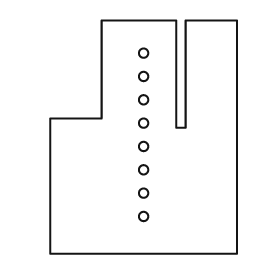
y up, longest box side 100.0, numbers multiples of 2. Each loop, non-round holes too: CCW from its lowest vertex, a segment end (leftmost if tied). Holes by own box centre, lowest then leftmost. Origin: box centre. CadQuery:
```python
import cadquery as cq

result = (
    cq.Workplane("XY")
    .moveTo(-40.0, -50.0)
    .lineTo(40.0, -50.0)
    .lineTo(40.0, 50.0)
    .lineTo(18.0, 50.0)
    .lineTo(18.0, 4.0)
    .lineTo(14.0, 4.0)
    .lineTo(14.0, 50.0)
    .lineTo(-18.0, 50.0)
    .lineTo(-18.0, 8.0)
    .lineTo(-40.0, 8.0)
    .close()
    .moveTo(0.0, -34.0)
    .circle(2.0)
    .moveTo(0.0, -24.0)
    .circle(2.0)
    .moveTo(0.0, -14.0)
    .circle(2.0)
    .moveTo(0.0, -4.0)
    .circle(2.0)
    .moveTo(0.0, 6.0)
    .circle(2.0)
    .moveTo(0.0, 16.0)
    .circle(2.0)
    .moveTo(0.0, 26.0)
    .circle(2.0)
    .moveTo(0.0, 36.0)
    .circle(2.0)
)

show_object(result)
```